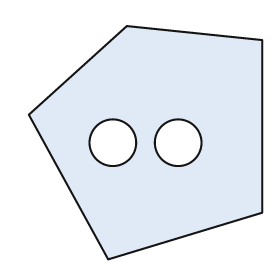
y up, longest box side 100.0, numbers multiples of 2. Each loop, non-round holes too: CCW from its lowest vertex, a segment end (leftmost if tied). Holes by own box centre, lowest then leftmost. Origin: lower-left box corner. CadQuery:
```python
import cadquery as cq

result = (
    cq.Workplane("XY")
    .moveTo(34.0, 0.0)
    .lineTo(100.0, 20.0)
    .lineTo(100.0, 94.0)
    .lineTo(42.0, 100.0)
    .lineTo(0.0, 62.0)
    .close()
    .moveTo(36.0, 50.0)
    .circle(10.0)
    .moveTo(64.0, 50.0)
    .circle(10.0)
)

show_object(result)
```